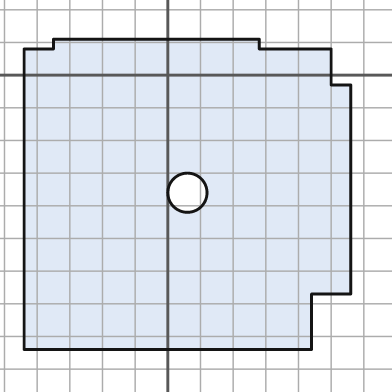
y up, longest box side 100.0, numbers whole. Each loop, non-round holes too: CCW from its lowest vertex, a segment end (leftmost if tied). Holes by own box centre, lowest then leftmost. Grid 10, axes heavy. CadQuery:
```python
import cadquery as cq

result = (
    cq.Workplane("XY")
    .moveTo(-44.0, -84.0)
    .lineTo(44.0, -84.0)
    .lineTo(44.0, -67.0)
    .lineTo(56.0, -67.0)
    .lineTo(56.0, -3.0)
    .lineTo(50.0, -3.0)
    .lineTo(50.0, 8.0)
    .lineTo(28.0, 8.0)
    .lineTo(28.0, 11.0)
    .lineTo(-35.0, 11.0)
    .lineTo(-35.0, 8.0)
    .lineTo(-44.0, 8.0)
    .close()
    .moveTo(6.0, -36.0)
    .circle(6.0)
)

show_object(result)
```